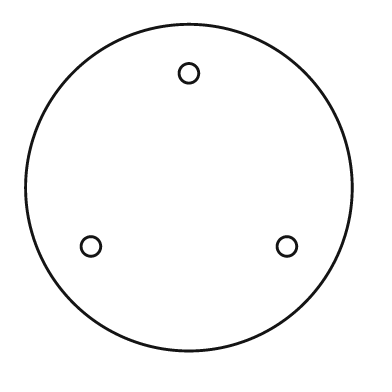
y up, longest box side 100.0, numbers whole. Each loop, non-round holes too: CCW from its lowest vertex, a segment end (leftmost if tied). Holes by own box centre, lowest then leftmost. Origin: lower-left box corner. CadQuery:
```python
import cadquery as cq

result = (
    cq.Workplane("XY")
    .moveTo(50.0, 50.0)
    .circle(50.0)
    .moveTo(20.0, 32.0)
    .circle(3.0)
    .moveTo(80.0, 32.0)
    .circle(3.0)
    .moveTo(50.0, 85.0)
    .circle(3.0)
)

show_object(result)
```